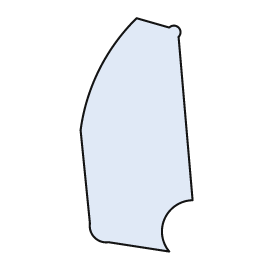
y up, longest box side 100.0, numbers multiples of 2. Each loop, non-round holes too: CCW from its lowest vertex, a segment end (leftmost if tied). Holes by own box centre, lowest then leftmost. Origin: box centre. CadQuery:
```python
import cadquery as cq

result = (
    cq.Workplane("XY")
    .moveTo(14.0, -50.0)
    .threePointArc((12.0, -36.0), (24.0, -28.0))
    .lineTo(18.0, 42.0)
    .threePointArc((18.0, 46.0), (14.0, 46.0))
    .lineTo(0.0, 50.0)
    .threePointArc((-16.0, 28.0), (-24.0, 2.0))
    .lineTo(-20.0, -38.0)
    .threePointArc((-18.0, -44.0), (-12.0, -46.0))
    .close()
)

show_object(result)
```